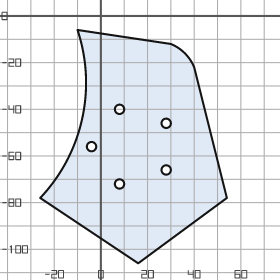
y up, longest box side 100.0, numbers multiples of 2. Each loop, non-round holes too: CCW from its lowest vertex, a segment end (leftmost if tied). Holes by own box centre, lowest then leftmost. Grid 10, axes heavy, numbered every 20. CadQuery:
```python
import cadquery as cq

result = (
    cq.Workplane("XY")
    .moveTo(16.0, -106.0)
    .lineTo(54.0, -78.0)
    .lineTo(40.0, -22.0)
    .threePointArc((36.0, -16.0), (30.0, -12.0))
    .lineTo(-10.0, -6.0)
    .threePointArc((-8.0, -44.0), (-26.0, -78.0))
    .close()
    .moveTo(8.0, -72.0)
    .circle(2.0)
    .moveTo(28.0, -66.0)
    .circle(2.0)
    .moveTo(-4.0, -56.0)
    .circle(2.0)
    .moveTo(28.0, -46.0)
    .circle(2.0)
    .moveTo(8.0, -40.0)
    .circle(2.0)
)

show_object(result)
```